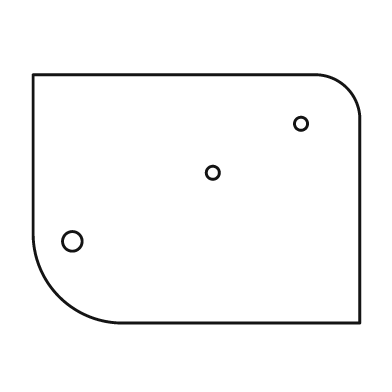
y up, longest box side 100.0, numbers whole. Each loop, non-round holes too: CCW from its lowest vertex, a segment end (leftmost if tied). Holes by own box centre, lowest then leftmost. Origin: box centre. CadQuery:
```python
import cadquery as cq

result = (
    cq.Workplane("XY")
    .moveTo(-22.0, -38.0)
    .lineTo(50.0, -38.0)
    .lineTo(50.0, 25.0)
    .threePointArc((46.0, 34.0), (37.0, 38.0))
    .lineTo(-50.0, 38.0)
    .lineTo(-50.0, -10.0)
    .threePointArc((-42.0, -30.0), (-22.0, -38.0))
    .close()
    .moveTo(-38.0, -13.0)
    .circle(3.0)
    .moveTo(5.0, 8.0)
    .circle(2.0)
    .moveTo(32.0, 23.0)
    .circle(2.0)
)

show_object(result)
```